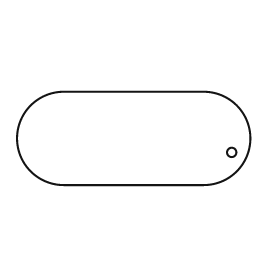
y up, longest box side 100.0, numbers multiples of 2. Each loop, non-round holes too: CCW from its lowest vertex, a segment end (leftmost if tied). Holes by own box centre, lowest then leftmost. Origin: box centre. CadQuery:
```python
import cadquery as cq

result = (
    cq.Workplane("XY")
    .moveTo(-30.0, -20.0)
    .lineTo(30.0, -20.0)
    .threePointArc((50.0, 0.0), (30.0, 20.0))
    .lineTo(-30.0, 20.0)
    .threePointArc((-50.0, 0.0), (-30.0, -20.0))
    .close()
    .moveTo(42.0, -6.0)
    .circle(2.0)
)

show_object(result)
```